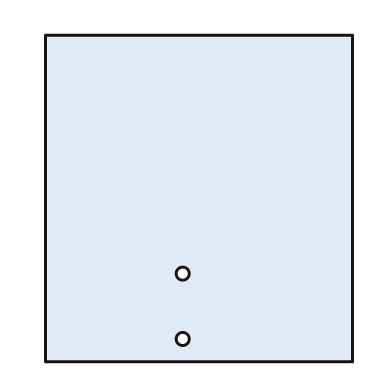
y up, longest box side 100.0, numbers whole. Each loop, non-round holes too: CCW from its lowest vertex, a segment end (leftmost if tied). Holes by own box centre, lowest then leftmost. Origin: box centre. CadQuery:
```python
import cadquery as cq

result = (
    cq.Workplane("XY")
    .moveTo(-47.0, -50.0)
    .lineTo(47.0, -50.0)
    .lineTo(47.0, 50.0)
    .lineTo(-47.0, 50.0)
    .close()
    .moveTo(-5.0, -43.0)
    .circle(2.0)
    .moveTo(-5.0, -23.0)
    .circle(2.0)
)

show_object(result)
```